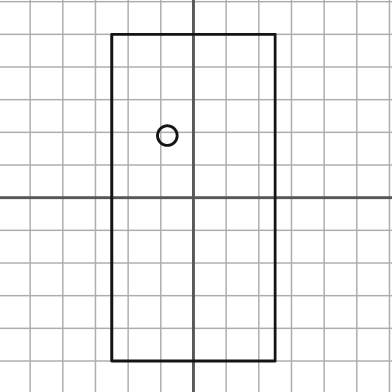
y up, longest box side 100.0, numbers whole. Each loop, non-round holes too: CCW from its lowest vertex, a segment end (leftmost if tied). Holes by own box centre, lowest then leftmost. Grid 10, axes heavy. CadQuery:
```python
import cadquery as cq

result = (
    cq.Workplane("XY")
    .moveTo(-25.0, -50.0)
    .lineTo(25.0, -50.0)
    .lineTo(25.0, 50.0)
    .lineTo(-25.0, 50.0)
    .close()
    .moveTo(-8.0, 19.0)
    .circle(3.0)
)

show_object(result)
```